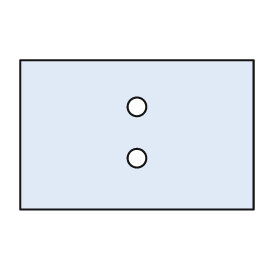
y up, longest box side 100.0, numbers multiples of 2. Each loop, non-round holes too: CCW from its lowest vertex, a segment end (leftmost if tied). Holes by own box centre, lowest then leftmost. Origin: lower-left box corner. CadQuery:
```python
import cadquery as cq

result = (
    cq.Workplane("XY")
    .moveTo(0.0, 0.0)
    .lineTo(100.0, 0.0)
    .lineTo(100.0, 64.0)
    .lineTo(0.0, 64.0)
    .close()
    .moveTo(50.0, 22.0)
    .circle(4.0)
    .moveTo(50.0, 44.0)
    .circle(4.0)
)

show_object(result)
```